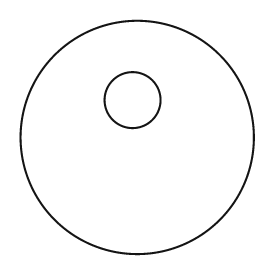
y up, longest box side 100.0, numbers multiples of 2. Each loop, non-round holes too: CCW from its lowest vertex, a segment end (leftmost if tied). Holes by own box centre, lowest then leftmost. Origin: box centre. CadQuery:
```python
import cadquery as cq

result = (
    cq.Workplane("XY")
    .moveTo(0.0, 0.0)
    .circle(50.0)
    .moveTo(-2.0, 16.0)
    .circle(12.0)
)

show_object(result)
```